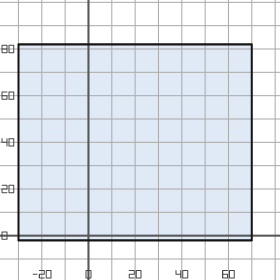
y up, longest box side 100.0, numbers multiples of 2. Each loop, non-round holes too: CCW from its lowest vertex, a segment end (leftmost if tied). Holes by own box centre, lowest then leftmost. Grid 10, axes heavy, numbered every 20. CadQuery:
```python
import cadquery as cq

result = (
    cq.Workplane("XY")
    .moveTo(-30.0, -2.0)
    .lineTo(70.0, -2.0)
    .lineTo(70.0, 82.0)
    .lineTo(-30.0, 82.0)
    .close()
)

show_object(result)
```